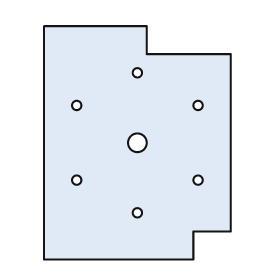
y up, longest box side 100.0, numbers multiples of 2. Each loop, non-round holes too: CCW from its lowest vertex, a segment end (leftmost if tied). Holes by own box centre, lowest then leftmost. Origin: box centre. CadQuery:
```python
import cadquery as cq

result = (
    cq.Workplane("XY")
    .moveTo(-40.0, -50.0)
    .lineTo(24.0, -50.0)
    .lineTo(24.0, -38.0)
    .lineTo(40.0, -38.0)
    .lineTo(40.0, 38.0)
    .lineTo(4.0, 38.0)
    .lineTo(4.0, 50.0)
    .lineTo(-40.0, 50.0)
    .close()
    .moveTo(0.0, -30.0)
    .circle(2.0)
    .moveTo(-26.0, -16.0)
    .circle(2.0)
    .moveTo(26.0, -16.0)
    .circle(2.0)
    .moveTo(0.0, 0.0)
    .circle(4.0)
    .moveTo(-26.0, 16.0)
    .circle(2.0)
    .moveTo(26.0, 16.0)
    .circle(2.0)
    .moveTo(0.0, 30.0)
    .circle(2.0)
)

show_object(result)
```